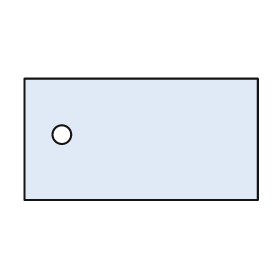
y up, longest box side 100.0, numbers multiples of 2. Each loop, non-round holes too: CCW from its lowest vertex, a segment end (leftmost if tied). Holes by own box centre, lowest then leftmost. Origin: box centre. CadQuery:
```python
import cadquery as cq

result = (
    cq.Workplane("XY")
    .moveTo(-50.0, -26.0)
    .lineTo(50.0, -26.0)
    .lineTo(50.0, 26.0)
    .lineTo(-50.0, 26.0)
    .close()
    .moveTo(-34.0, 2.0)
    .circle(4.0)
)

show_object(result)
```